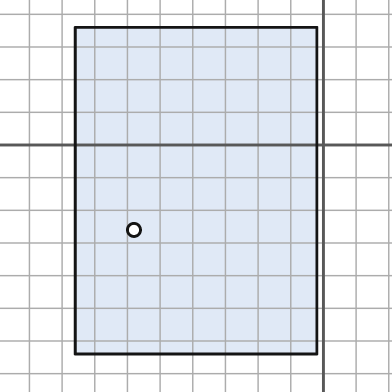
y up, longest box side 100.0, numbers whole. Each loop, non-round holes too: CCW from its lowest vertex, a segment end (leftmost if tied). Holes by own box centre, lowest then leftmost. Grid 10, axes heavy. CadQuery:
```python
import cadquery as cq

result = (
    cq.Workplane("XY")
    .moveTo(-76.0, -64.0)
    .lineTo(-2.0, -64.0)
    .lineTo(-2.0, 36.0)
    .lineTo(-76.0, 36.0)
    .close()
    .moveTo(-58.0, -26.0)
    .circle(2.0)
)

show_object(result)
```